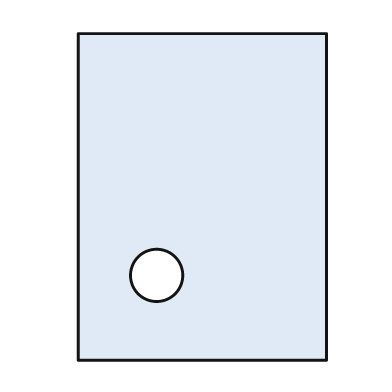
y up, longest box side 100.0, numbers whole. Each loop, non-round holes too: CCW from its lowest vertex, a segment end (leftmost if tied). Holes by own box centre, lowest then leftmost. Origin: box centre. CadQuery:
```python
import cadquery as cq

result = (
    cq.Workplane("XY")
    .moveTo(-38.0, -50.0)
    .lineTo(38.0, -50.0)
    .lineTo(38.0, 50.0)
    .lineTo(-38.0, 50.0)
    .close()
    .moveTo(-14.0, -24.0)
    .circle(8.0)
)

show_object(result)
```